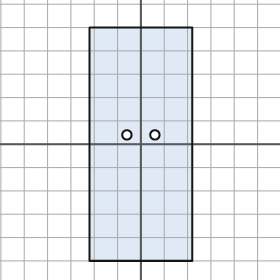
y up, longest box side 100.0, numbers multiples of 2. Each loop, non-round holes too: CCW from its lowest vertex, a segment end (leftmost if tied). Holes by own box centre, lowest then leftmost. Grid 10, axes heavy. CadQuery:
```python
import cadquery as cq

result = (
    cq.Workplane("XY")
    .moveTo(-22.0, -50.0)
    .lineTo(22.0, -50.0)
    .lineTo(22.0, 50.0)
    .lineTo(-22.0, 50.0)
    .close()
    .moveTo(-6.0, 4.0)
    .circle(2.0)
    .moveTo(6.0, 4.0)
    .circle(2.0)
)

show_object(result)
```